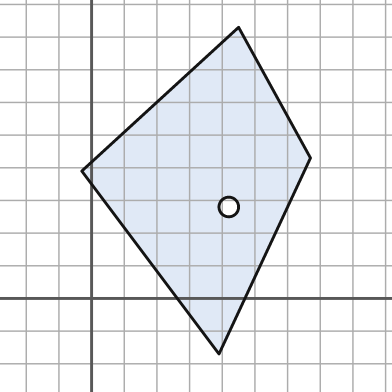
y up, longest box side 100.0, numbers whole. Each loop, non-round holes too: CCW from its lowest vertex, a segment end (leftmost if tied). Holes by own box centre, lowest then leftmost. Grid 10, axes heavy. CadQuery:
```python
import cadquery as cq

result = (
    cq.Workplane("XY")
    .moveTo(39.0, -17.0)
    .lineTo(67.0, 43.0)
    .lineTo(45.0, 83.0)
    .lineTo(-3.0, 39.0)
    .close()
    .moveTo(42.0, 28.0)
    .circle(3.0)
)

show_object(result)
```